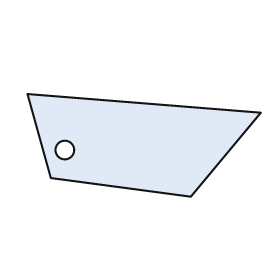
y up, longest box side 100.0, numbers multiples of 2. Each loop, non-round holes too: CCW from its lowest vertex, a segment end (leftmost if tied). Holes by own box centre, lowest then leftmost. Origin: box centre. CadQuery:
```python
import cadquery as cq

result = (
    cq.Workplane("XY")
    .moveTo(20.0, -22.0)
    .lineTo(50.0, 14.0)
    .lineTo(-50.0, 22.0)
    .lineTo(-40.0, -14.0)
    .close()
    .moveTo(-34.0, -2.0)
    .circle(4.0)
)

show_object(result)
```